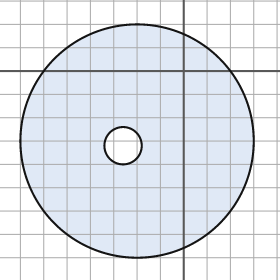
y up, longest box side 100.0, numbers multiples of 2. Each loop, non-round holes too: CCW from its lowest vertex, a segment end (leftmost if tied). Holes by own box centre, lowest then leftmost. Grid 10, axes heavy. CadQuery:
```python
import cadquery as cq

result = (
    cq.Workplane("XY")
    .moveTo(-20.0, -30.0)
    .circle(50.0)
    .moveTo(-26.0, -32.0)
    .circle(8.0)
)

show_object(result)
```